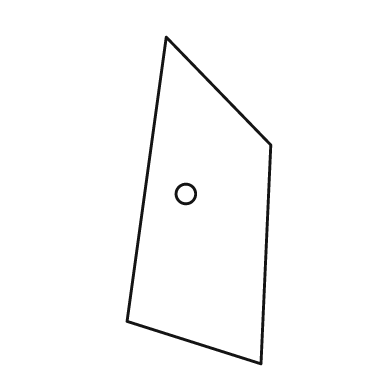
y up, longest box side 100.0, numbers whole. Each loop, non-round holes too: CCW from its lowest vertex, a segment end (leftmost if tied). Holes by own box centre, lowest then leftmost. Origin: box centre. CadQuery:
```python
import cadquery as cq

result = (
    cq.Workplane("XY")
    .moveTo(19.0, -50.0)
    .lineTo(22.0, 17.0)
    .lineTo(-10.0, 50.0)
    .lineTo(-22.0, -37.0)
    .close()
    .moveTo(-4.0, 2.0)
    .circle(3.0)
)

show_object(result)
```